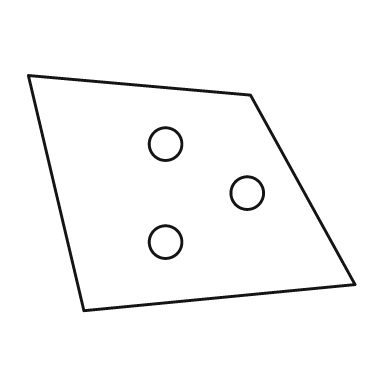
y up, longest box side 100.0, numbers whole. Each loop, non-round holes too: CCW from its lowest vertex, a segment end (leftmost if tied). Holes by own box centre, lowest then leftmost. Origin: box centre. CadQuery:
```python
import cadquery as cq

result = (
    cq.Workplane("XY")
    .moveTo(-33.0, -36.0)
    .lineTo(50.0, -28.0)
    .lineTo(18.0, 30.0)
    .lineTo(-50.0, 36.0)
    .close()
    .moveTo(-8.0, -15.0)
    .circle(5.0)
    .moveTo(17.0, 0.0)
    .circle(5.0)
    .moveTo(-8.0, 15.0)
    .circle(5.0)
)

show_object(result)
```